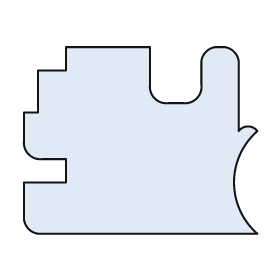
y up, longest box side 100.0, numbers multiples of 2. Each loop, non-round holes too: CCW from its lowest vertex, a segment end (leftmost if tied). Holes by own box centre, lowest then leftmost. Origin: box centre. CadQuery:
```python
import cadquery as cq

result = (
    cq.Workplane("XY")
    .moveTo(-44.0, -40.0)
    .lineTo(50.0, -40.0)
    .threePointArc((40.0, -18.0), (50.0, 4.0))
    .threePointArc((46.0, 6.0), (42.0, 4.0))
    .lineTo(42.0, 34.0)
    .threePointArc((40.0, 38.0), (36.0, 40.0))
    .lineTo(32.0, 40.0)
    .threePointArc((28.0, 38.0), (26.0, 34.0))
    .lineTo(26.0, 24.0)
    .threePointArc((24.0, 18.0), (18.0, 16.0))
    .lineTo(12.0, 16.0)
    .threePointArc((6.0, 18.0), (4.0, 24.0))
    .lineTo(4.0, 40.0)
    .lineTo(-32.0, 40.0)
    .lineTo(-32.0, 30.0)
    .lineTo(-44.0, 30.0)
    .lineTo(-44.0, 12.0)
    .lineTo(-50.0, 12.0)
    .lineTo(-50.0, 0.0)
    .threePointArc((-48.0, -6.0), (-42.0, -8.0))
    .lineTo(-32.0, -8.0)
    .lineTo(-32.0, -18.0)
    .lineTo(-50.0, -18.0)
    .lineTo(-50.0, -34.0)
    .threePointArc((-48.0, -38.0), (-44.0, -40.0))
    .close()
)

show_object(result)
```